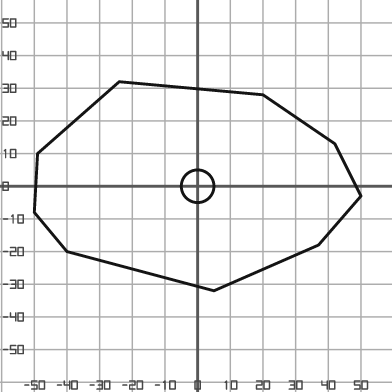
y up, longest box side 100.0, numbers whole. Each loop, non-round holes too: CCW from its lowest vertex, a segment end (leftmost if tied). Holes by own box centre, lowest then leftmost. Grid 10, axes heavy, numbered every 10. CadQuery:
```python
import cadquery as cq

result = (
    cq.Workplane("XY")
    .moveTo(5.0, -32.0)
    .lineTo(37.0, -18.0)
    .lineTo(50.0, -3.0)
    .lineTo(42.0, 13.0)
    .lineTo(20.0, 28.0)
    .lineTo(-24.0, 32.0)
    .lineTo(-49.0, 10.0)
    .lineTo(-50.0, -8.0)
    .lineTo(-40.0, -20.0)
    .close()
    .moveTo(0.0, 0.0)
    .circle(5.0)
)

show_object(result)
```